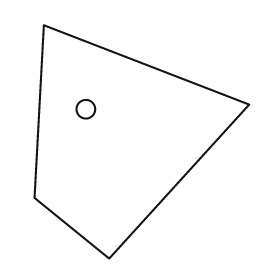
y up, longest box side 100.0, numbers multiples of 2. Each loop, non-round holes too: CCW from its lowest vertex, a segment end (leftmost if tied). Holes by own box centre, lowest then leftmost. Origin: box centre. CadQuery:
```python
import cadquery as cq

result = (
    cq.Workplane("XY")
    .moveTo(-14.0, -50.0)
    .lineTo(46.0, 16.0)
    .lineTo(-42.0, 50.0)
    .lineTo(-46.0, -24.0)
    .close()
    .moveTo(-24.0, 14.0)
    .circle(4.0)
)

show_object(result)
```